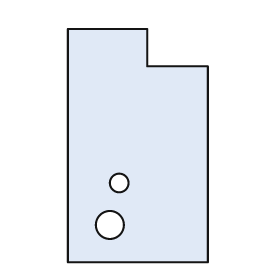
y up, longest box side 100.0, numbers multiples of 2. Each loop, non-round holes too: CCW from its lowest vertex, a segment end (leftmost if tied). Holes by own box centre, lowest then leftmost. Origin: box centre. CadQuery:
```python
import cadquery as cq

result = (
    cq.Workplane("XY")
    .moveTo(-30.0, -50.0)
    .lineTo(30.0, -50.0)
    .lineTo(30.0, 34.0)
    .lineTo(4.0, 34.0)
    .lineTo(4.0, 50.0)
    .lineTo(-30.0, 50.0)
    .close()
    .moveTo(-12.0, -34.0)
    .circle(6.0)
    .moveTo(-8.0, -16.0)
    .circle(4.0)
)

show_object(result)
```